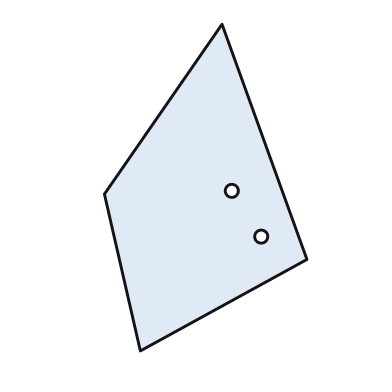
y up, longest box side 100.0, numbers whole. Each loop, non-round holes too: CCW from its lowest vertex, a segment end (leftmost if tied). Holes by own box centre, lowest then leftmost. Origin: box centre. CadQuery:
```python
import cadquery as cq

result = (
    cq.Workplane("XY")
    .moveTo(-20.0, -50.0)
    .lineTo(31.0, -22.0)
    .lineTo(5.0, 50.0)
    .lineTo(-31.0, -2.0)
    .close()
    .moveTo(17.0, -15.0)
    .circle(2.0)
    .moveTo(8.0, -1.0)
    .circle(2.0)
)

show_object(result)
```